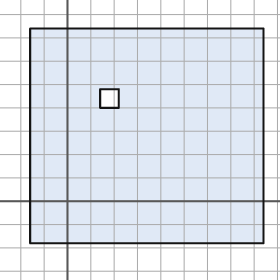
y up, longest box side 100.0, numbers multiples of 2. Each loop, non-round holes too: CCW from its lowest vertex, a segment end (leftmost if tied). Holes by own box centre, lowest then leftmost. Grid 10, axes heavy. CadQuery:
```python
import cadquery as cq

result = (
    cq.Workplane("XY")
    .moveTo(-16.0, -18.0)
    .lineTo(84.0, -18.0)
    .lineTo(84.0, 74.0)
    .lineTo(-16.0, 74.0)
    .close()
    .moveTo(14.0, 40.0)
    .lineTo(22.0, 40.0)
    .lineTo(22.0, 48.0)
    .lineTo(14.0, 48.0)
    .close()
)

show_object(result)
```